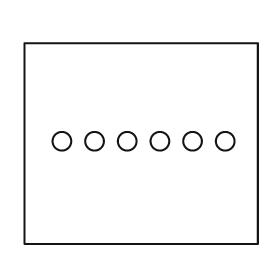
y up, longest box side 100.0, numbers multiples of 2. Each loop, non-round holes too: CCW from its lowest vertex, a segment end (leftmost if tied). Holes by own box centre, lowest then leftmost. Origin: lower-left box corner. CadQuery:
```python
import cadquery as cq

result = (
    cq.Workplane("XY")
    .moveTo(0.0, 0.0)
    .lineTo(100.0, 0.0)
    .lineTo(100.0, 86.0)
    .lineTo(0.0, 86.0)
    .close()
    .moveTo(16.0, 44.0)
    .circle(4.0)
    .moveTo(30.0, 44.0)
    .circle(4.0)
    .moveTo(44.0, 44.0)
    .circle(4.0)
    .moveTo(58.0, 44.0)
    .circle(4.0)
    .moveTo(72.0, 44.0)
    .circle(4.0)
    .moveTo(86.0, 44.0)
    .circle(4.0)
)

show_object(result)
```